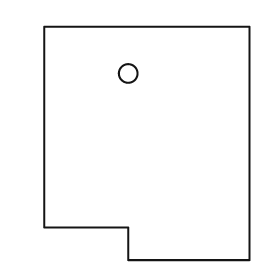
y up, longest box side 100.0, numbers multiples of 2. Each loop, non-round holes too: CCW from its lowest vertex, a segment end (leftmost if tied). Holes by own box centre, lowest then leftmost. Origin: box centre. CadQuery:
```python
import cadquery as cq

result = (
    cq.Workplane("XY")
    .moveTo(-8.0, -50.0)
    .lineTo(44.0, -50.0)
    .lineTo(44.0, 50.0)
    .lineTo(-44.0, 50.0)
    .lineTo(-44.0, -36.0)
    .lineTo(-8.0, -36.0)
    .close()
    .moveTo(-8.0, 30.0)
    .circle(4.0)
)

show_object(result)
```